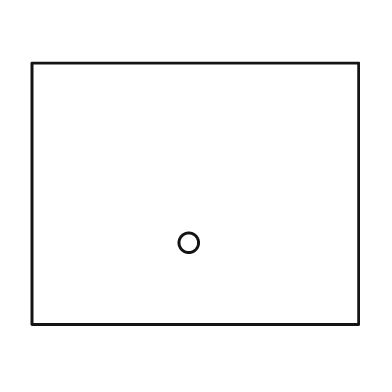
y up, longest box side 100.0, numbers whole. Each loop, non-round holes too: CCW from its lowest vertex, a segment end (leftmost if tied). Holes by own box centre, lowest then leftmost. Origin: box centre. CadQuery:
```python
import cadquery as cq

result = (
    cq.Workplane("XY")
    .moveTo(-50.0, -40.0)
    .lineTo(50.0, -40.0)
    .lineTo(50.0, 40.0)
    .lineTo(-50.0, 40.0)
    .close()
    .moveTo(-2.0, -15.0)
    .circle(3.0)
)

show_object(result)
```